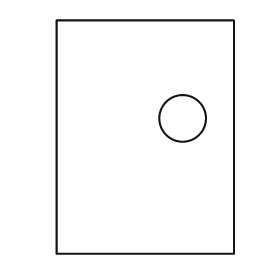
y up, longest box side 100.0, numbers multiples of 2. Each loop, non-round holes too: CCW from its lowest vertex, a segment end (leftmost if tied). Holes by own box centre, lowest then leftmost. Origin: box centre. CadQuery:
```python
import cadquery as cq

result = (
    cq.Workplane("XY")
    .moveTo(-38.0, -50.0)
    .lineTo(38.0, -50.0)
    .lineTo(38.0, 50.0)
    .lineTo(-38.0, 50.0)
    .close()
    .moveTo(16.0, 8.0)
    .circle(10.0)
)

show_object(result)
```